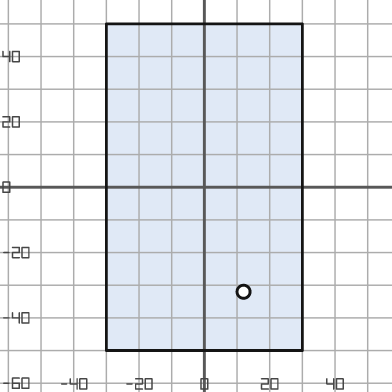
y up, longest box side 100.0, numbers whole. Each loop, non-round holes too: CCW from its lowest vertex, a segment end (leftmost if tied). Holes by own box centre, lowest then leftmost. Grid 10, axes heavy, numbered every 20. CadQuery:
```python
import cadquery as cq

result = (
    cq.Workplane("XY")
    .moveTo(-30.0, -50.0)
    .lineTo(30.0, -50.0)
    .lineTo(30.0, 50.0)
    .lineTo(-30.0, 50.0)
    .close()
    .moveTo(12.0, -32.0)
    .circle(2.0)
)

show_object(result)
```